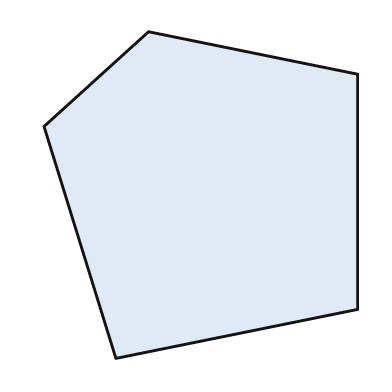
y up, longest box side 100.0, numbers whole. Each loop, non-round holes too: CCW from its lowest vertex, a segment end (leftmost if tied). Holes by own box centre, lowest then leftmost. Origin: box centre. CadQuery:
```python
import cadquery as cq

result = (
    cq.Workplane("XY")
    .moveTo(-26.0, -50.0)
    .lineTo(48.0, -35.0)
    .lineTo(48.0, 37.0)
    .lineTo(-16.0, 50.0)
    .lineTo(-48.0, 21.0)
    .close()
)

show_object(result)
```